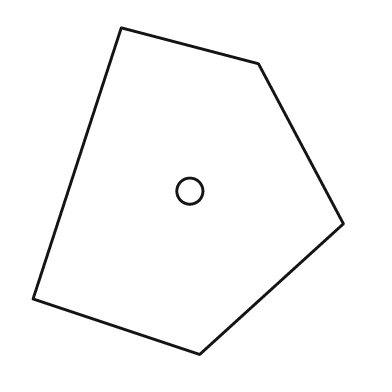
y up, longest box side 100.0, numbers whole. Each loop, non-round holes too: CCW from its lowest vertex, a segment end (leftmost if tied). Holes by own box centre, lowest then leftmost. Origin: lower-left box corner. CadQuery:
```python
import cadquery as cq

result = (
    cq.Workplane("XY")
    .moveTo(51.0, 0.0)
    .lineTo(95.0, 40.0)
    .lineTo(69.0, 89.0)
    .lineTo(27.0, 100.0)
    .lineTo(0.0, 17.0)
    .close()
    .moveTo(48.0, 50.0)
    .circle(4.0)
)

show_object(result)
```